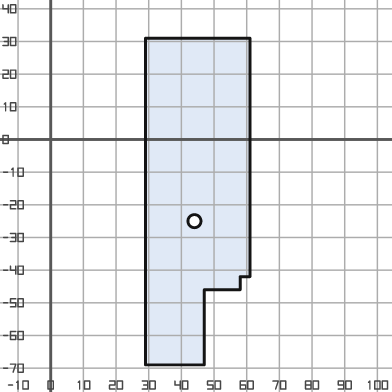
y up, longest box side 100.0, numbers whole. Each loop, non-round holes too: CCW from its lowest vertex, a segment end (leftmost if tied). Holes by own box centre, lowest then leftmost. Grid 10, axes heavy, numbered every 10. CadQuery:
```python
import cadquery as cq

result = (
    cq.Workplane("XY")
    .moveTo(29.0, -69.0)
    .lineTo(47.0, -69.0)
    .lineTo(47.0, -46.0)
    .lineTo(58.0, -46.0)
    .lineTo(58.0, -42.0)
    .lineTo(61.0, -42.0)
    .lineTo(61.0, 31.0)
    .lineTo(29.0, 31.0)
    .close()
    .moveTo(44.0, -25.0)
    .circle(2.0)
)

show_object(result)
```